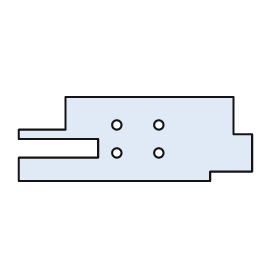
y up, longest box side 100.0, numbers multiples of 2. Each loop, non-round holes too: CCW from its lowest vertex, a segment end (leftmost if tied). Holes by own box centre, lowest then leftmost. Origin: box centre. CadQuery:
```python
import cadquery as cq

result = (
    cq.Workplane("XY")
    .moveTo(-50.0, -18.0)
    .lineTo(32.0, -18.0)
    .lineTo(32.0, -14.0)
    .lineTo(50.0, -14.0)
    .lineTo(50.0, 2.0)
    .lineTo(42.0, 2.0)
    .lineTo(42.0, 18.0)
    .lineTo(-30.0, 18.0)
    .lineTo(-30.0, 4.0)
    .lineTo(-50.0, 4.0)
    .lineTo(-50.0, 0.0)
    .lineTo(-16.0, 0.0)
    .lineTo(-16.0, -8.0)
    .lineTo(-50.0, -8.0)
    .close()
    .moveTo(-8.0, -6.0)
    .circle(2.0)
    .moveTo(10.0, -6.0)
    .circle(2.0)
    .moveTo(-8.0, 6.0)
    .circle(2.0)
    .moveTo(10.0, 6.0)
    .circle(2.0)
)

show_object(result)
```